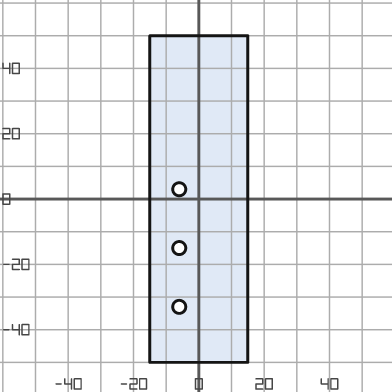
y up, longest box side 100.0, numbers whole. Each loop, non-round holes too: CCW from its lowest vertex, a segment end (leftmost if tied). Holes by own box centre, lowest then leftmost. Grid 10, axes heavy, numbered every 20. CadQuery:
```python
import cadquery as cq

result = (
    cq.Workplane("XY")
    .moveTo(-15.0, -50.0)
    .lineTo(15.0, -50.0)
    .lineTo(15.0, 50.0)
    .lineTo(-15.0, 50.0)
    .close()
    .moveTo(-6.0, -33.0)
    .circle(2.0)
    .moveTo(-6.0, -15.0)
    .circle(2.0)
    .moveTo(-6.0, 3.0)
    .circle(2.0)
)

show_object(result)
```